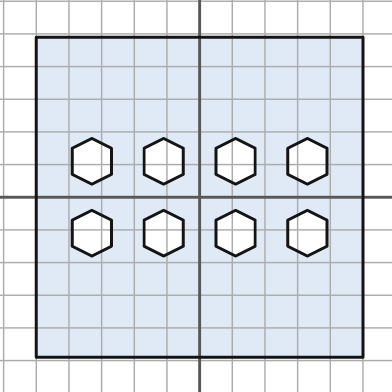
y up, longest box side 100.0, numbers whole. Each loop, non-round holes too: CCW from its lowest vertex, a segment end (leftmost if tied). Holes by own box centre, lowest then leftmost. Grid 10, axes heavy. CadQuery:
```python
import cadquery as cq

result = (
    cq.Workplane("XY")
    .moveTo(-50.0, -49.0)
    .lineTo(50.0, -49.0)
    .lineTo(50.0, 49.0)
    .lineTo(-50.0, 49.0)
    .close()
    .moveTo(-33.0, -18.0)
    .lineTo(-27.0, -15.0)
    .lineTo(-27.0, -7.0)
    .lineTo(-33.0, -4.0)
    .lineTo(-39.0, -7.0)
    .lineTo(-39.0, -15.0)
    .close()
    .moveTo(-11.0, -18.0)
    .lineTo(-5.0, -15.0)
    .lineTo(-5.0, -7.0)
    .lineTo(-11.0, -4.0)
    .lineTo(-17.0, -7.0)
    .lineTo(-17.0, -15.0)
    .close()
    .moveTo(11.0, -18.0)
    .lineTo(17.0, -15.0)
    .lineTo(17.0, -7.0)
    .lineTo(11.0, -4.0)
    .lineTo(5.0, -7.0)
    .lineTo(5.0, -15.0)
    .close()
    .moveTo(33.0, -18.0)
    .lineTo(39.0, -15.0)
    .lineTo(39.0, -7.0)
    .lineTo(33.0, -4.0)
    .lineTo(27.0, -7.0)
    .lineTo(27.0, -15.0)
    .close()
    .moveTo(-33.0, 4.0)
    .lineTo(-27.0, 7.0)
    .lineTo(-27.0, 15.0)
    .lineTo(-33.0, 18.0)
    .lineTo(-39.0, 15.0)
    .lineTo(-39.0, 7.0)
    .close()
    .moveTo(-11.0, 4.0)
    .lineTo(-5.0, 7.0)
    .lineTo(-5.0, 15.0)
    .lineTo(-11.0, 18.0)
    .lineTo(-17.0, 15.0)
    .lineTo(-17.0, 7.0)
    .close()
    .moveTo(11.0, 4.0)
    .lineTo(17.0, 7.0)
    .lineTo(17.0, 15.0)
    .lineTo(11.0, 18.0)
    .lineTo(5.0, 15.0)
    .lineTo(5.0, 7.0)
    .close()
    .moveTo(33.0, 4.0)
    .lineTo(39.0, 7.0)
    .lineTo(39.0, 15.0)
    .lineTo(33.0, 18.0)
    .lineTo(27.0, 15.0)
    .lineTo(27.0, 7.0)
    .close()
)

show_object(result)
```